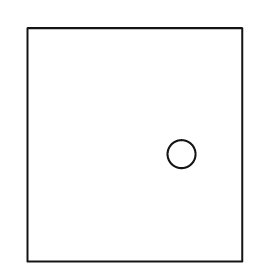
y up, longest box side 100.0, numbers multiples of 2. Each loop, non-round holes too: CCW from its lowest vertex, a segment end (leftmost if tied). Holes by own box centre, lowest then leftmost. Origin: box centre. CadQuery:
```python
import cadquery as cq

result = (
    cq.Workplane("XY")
    .moveTo(-46.0, -50.0)
    .lineTo(46.0, -50.0)
    .lineTo(46.0, 50.0)
    .lineTo(-46.0, 50.0)
    .close()
    .moveTo(20.0, -4.0)
    .circle(6.0)
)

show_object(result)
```